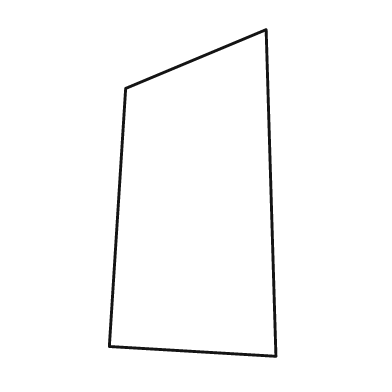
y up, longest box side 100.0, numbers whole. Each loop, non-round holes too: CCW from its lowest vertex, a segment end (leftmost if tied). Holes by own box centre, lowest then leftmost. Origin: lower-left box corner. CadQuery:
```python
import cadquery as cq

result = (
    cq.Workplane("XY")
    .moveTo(51.0, 0.0)
    .lineTo(48.0, 100.0)
    .lineTo(5.0, 82.0)
    .lineTo(0.0, 3.0)
    .close()
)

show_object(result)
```